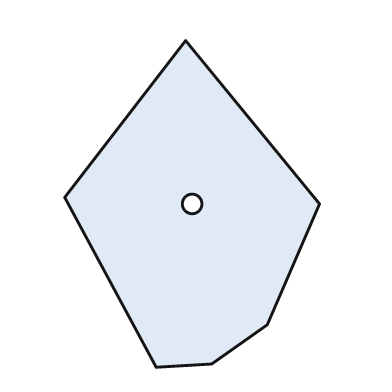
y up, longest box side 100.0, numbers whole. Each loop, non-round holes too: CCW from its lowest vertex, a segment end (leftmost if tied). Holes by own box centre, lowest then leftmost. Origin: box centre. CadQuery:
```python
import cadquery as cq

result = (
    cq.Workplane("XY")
    .moveTo(-11.0, -50.0)
    .lineTo(6.0, -49.0)
    .lineTo(23.0, -37.0)
    .lineTo(39.0, 0.0)
    .lineTo(-2.0, 50.0)
    .lineTo(-39.0, 2.0)
    .close()
    .moveTo(0.0, 0.0)
    .circle(3.0)
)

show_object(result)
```